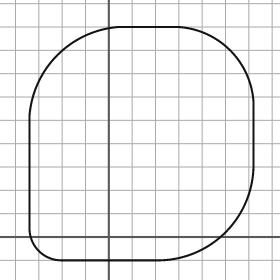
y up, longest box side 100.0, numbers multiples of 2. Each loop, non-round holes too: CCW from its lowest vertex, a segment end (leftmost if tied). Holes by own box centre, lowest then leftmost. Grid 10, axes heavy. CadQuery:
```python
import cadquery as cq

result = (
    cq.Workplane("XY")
    .moveTo(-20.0, -10.0)
    .lineTo(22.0, -10.0)
    .threePointArc((50.0, 2.0), (62.0, 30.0))
    .lineTo(62.0, 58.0)
    .threePointArc((52.0, 80.0), (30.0, 90.0))
    .lineTo(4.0, 90.0)
    .threePointArc((-22.0, 78.0), (-34.0, 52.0))
    .lineTo(-34.0, 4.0)
    .threePointArc((-30.0, -6.0), (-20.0, -10.0))
    .close()
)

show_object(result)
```